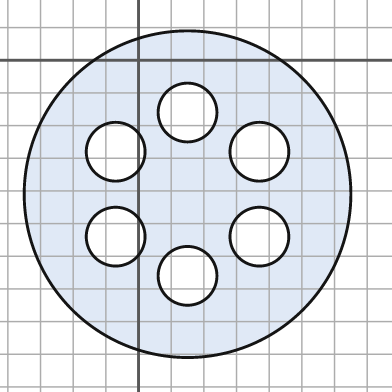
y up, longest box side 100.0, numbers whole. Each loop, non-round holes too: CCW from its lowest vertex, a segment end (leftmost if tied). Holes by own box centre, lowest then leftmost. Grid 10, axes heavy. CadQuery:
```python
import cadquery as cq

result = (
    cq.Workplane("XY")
    .moveTo(15.0, -41.0)
    .circle(50.0)
    .moveTo(15.0, -66.0)
    .circle(9.0)
    .moveTo(-7.0, -54.0)
    .circle(9.0)
    .moveTo(37.0, -54.0)
    .circle(9.0)
    .moveTo(-7.0, -28.0)
    .circle(9.0)
    .moveTo(37.0, -28.0)
    .circle(9.0)
    .moveTo(15.0, -16.0)
    .circle(9.0)
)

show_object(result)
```